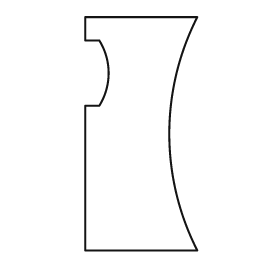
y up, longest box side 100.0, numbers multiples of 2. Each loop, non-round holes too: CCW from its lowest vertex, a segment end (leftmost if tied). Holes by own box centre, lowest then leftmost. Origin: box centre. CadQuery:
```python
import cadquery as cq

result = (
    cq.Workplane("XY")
    .moveTo(-24.0, -50.0)
    .lineTo(24.0, -50.0)
    .threePointArc((12.0, 0.0), (24.0, 50.0))
    .lineTo(-24.0, 50.0)
    .lineTo(-24.0, 40.0)
    .lineTo(-18.0, 40.0)
    .threePointArc((-14.0, 26.0), (-18.0, 12.0))
    .lineTo(-24.0, 12.0)
    .close()
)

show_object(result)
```